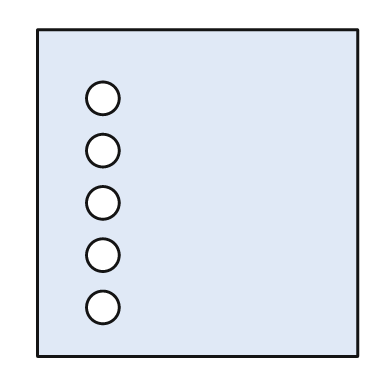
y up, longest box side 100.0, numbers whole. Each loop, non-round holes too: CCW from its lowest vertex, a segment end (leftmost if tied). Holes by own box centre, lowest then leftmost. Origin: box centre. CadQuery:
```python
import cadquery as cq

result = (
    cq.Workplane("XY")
    .moveTo(-49.0, -50.0)
    .lineTo(49.0, -50.0)
    .lineTo(49.0, 50.0)
    .lineTo(-49.0, 50.0)
    .close()
    .moveTo(-29.0, -35.0)
    .circle(5.0)
    .moveTo(-29.0, -19.0)
    .circle(5.0)
    .moveTo(-29.0, -3.0)
    .circle(5.0)
    .moveTo(-29.0, 13.0)
    .circle(5.0)
    .moveTo(-29.0, 29.0)
    .circle(5.0)
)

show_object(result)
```